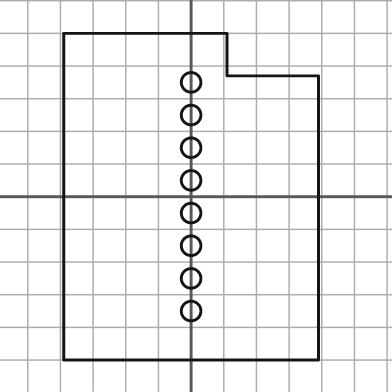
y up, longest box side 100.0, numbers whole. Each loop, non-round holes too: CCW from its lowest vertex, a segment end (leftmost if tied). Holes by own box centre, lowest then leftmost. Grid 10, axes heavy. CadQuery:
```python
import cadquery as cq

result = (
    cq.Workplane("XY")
    .moveTo(-39.0, -50.0)
    .lineTo(39.0, -50.0)
    .lineTo(39.0, 37.0)
    .lineTo(11.0, 37.0)
    .lineTo(11.0, 50.0)
    .lineTo(-39.0, 50.0)
    .close()
    .moveTo(0.0, -35.0)
    .circle(3.0)
    .moveTo(0.0, -25.0)
    .circle(3.0)
    .moveTo(0.0, -15.0)
    .circle(3.0)
    .moveTo(0.0, -5.0)
    .circle(3.0)
    .moveTo(0.0, 5.0)
    .circle(3.0)
    .moveTo(0.0, 15.0)
    .circle(3.0)
    .moveTo(0.0, 25.0)
    .circle(3.0)
    .moveTo(0.0, 35.0)
    .circle(3.0)
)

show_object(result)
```